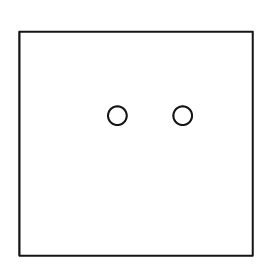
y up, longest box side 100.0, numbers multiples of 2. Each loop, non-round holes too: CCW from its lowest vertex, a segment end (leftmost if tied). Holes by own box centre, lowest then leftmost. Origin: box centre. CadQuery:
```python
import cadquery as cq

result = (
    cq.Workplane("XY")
    .moveTo(-50.0, -48.0)
    .lineTo(50.0, -48.0)
    .lineTo(50.0, 48.0)
    .lineTo(-50.0, 48.0)
    .close()
    .moveTo(-8.0, 12.0)
    .circle(4.0)
    .moveTo(20.0, 12.0)
    .circle(4.0)
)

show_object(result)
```